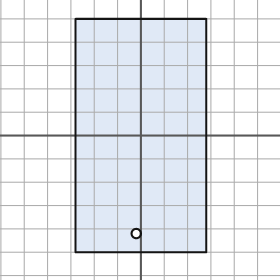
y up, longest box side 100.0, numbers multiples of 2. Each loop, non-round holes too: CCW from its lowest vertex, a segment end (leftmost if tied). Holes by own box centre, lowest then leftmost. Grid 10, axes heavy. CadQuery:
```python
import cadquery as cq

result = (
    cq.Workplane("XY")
    .moveTo(-28.0, -50.0)
    .lineTo(28.0, -50.0)
    .lineTo(28.0, 50.0)
    .lineTo(-28.0, 50.0)
    .close()
    .moveTo(-2.0, -42.0)
    .circle(2.0)
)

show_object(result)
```